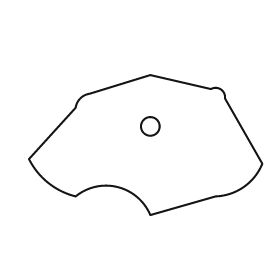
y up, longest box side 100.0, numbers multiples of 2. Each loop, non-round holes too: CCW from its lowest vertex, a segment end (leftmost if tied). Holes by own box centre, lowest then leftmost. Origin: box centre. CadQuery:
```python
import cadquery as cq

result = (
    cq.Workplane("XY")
    .moveTo(2.0, -30.0)
    .lineTo(30.0, -22.0)
    .threePointArc((42.0, -18.0), (50.0, -8.0))
    .lineTo(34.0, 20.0)
    .threePointArc((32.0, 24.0), (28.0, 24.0))
    .lineTo(2.0, 30.0)
    .lineTo(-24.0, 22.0)
    .threePointArc((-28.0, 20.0), (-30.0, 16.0))
    .lineTo(-50.0, -6.0)
    .threePointArc((-42.0, -16.0), (-30.0, -22.0))
    .threePointArc((-12.0, -18.0), (2.0, -30.0))
    .close()
    .moveTo(2.0, 8.0)
    .circle(4.0)
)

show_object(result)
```